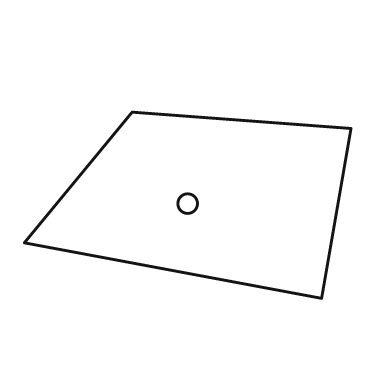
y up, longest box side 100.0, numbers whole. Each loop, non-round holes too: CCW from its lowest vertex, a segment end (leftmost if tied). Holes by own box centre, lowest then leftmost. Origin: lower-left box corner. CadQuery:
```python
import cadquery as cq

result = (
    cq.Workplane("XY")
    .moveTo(91.0, 0.0)
    .lineTo(100.0, 52.0)
    .lineTo(33.0, 57.0)
    .lineTo(0.0, 17.0)
    .close()
    .moveTo(50.0, 29.0)
    .circle(3.0)
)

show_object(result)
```